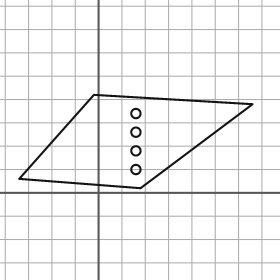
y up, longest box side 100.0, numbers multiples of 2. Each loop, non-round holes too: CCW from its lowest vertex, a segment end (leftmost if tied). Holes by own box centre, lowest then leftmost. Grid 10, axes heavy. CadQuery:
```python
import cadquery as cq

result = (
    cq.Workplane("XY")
    .moveTo(18.0, 2.0)
    .lineTo(66.0, 38.0)
    .lineTo(-2.0, 42.0)
    .lineTo(-34.0, 6.0)
    .close()
    .moveTo(16.0, 10.0)
    .circle(2.0)
    .moveTo(16.0, 18.0)
    .circle(2.0)
    .moveTo(16.0, 26.0)
    .circle(2.0)
    .moveTo(16.0, 34.0)
    .circle(2.0)
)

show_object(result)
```